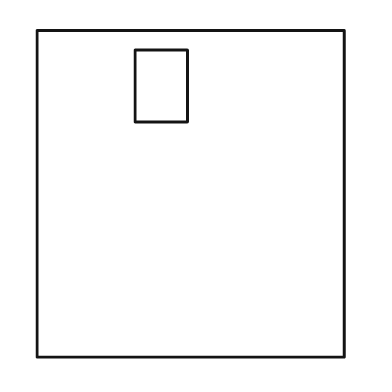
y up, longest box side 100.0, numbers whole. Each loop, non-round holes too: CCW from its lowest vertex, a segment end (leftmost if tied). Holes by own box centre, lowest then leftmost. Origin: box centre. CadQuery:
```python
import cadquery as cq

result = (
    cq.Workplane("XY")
    .moveTo(-47.0, -50.0)
    .lineTo(47.0, -50.0)
    .lineTo(47.0, 50.0)
    .lineTo(-47.0, 50.0)
    .close()
    .moveTo(-17.0, 22.0)
    .lineTo(-1.0, 22.0)
    .lineTo(-1.0, 44.0)
    .lineTo(-17.0, 44.0)
    .close()
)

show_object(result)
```